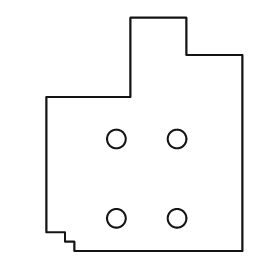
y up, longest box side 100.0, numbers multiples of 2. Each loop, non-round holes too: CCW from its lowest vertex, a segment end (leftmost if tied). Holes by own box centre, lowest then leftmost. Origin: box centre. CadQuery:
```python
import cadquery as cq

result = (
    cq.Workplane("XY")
    .moveTo(-30.0, -50.0)
    .lineTo(42.0, -50.0)
    .lineTo(42.0, 34.0)
    .lineTo(18.0, 34.0)
    .lineTo(18.0, 50.0)
    .lineTo(-6.0, 50.0)
    .lineTo(-6.0, 16.0)
    .lineTo(-42.0, 16.0)
    .lineTo(-42.0, -42.0)
    .lineTo(-34.0, -42.0)
    .lineTo(-34.0, -46.0)
    .lineTo(-30.0, -46.0)
    .close()
    .moveTo(-12.0, -36.0)
    .circle(4.0)
    .moveTo(14.0, -36.0)
    .circle(4.0)
    .moveTo(-12.0, -2.0)
    .circle(4.0)
    .moveTo(14.0, -2.0)
    .circle(4.0)
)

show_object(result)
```